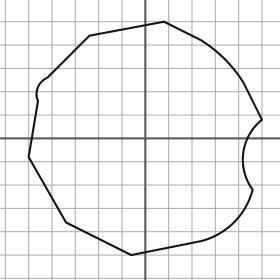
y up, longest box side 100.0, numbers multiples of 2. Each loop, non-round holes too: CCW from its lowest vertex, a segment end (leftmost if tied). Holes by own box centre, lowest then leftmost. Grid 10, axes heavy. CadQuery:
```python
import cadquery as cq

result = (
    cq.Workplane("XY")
    .moveTo(-6.0, -50.0)
    .lineTo(24.0, -44.0)
    .threePointArc((38.0, -36.0), (46.0, -22.0))
    .threePointArc((42.0, -6.0), (50.0, 8.0))
    .lineTo(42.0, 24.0)
    .threePointArc((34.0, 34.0), (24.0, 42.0))
    .lineTo(8.0, 50.0)
    .lineTo(-24.0, 44.0)
    .lineTo(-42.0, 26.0)
    .threePointArc((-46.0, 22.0), (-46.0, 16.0))
    .lineTo(-50.0, -8.0)
    .lineTo(-34.0, -36.0)
    .close()
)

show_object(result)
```